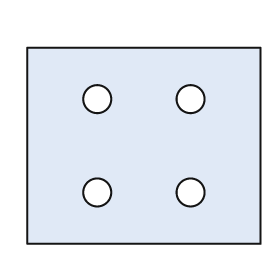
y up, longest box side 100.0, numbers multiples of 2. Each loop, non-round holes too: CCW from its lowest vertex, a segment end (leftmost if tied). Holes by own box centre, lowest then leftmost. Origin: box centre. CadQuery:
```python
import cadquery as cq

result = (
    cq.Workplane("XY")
    .moveTo(-50.0, -42.0)
    .lineTo(50.0, -42.0)
    .lineTo(50.0, 42.0)
    .lineTo(-50.0, 42.0)
    .close()
    .moveTo(-20.0, -20.0)
    .circle(6.0)
    .moveTo(20.0, -20.0)
    .circle(6.0)
    .moveTo(-20.0, 20.0)
    .circle(6.0)
    .moveTo(20.0, 20.0)
    .circle(6.0)
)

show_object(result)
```